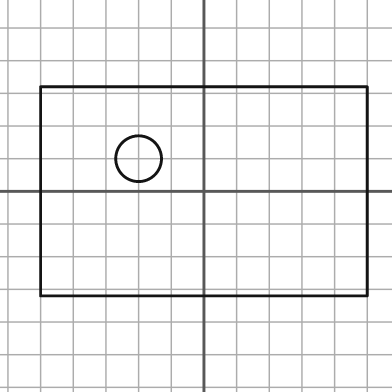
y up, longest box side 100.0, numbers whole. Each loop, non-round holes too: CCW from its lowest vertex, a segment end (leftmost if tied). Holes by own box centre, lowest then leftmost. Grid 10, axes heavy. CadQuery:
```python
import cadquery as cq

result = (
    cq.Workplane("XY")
    .moveTo(-50.0, -32.0)
    .lineTo(50.0, -32.0)
    .lineTo(50.0, 32.0)
    .lineTo(-50.0, 32.0)
    .close()
    .moveTo(-20.0, 10.0)
    .circle(7.0)
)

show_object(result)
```